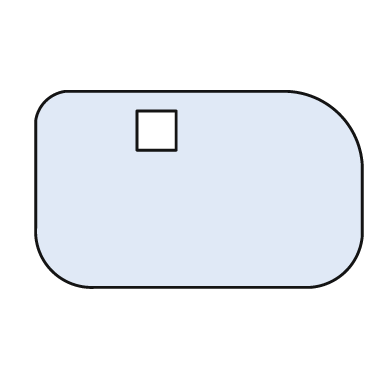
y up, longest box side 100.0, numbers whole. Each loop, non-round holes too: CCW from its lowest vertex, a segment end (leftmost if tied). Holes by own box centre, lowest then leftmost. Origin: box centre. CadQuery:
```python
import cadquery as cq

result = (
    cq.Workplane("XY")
    .moveTo(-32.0, -30.0)
    .lineTo(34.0, -30.0)
    .threePointArc((45.0, -25.0), (50.0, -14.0))
    .lineTo(50.0, 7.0)
    .threePointArc((43.0, 23.0), (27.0, 30.0))
    .lineTo(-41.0, 30.0)
    .threePointArc((-47.0, 27.0), (-50.0, 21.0))
    .lineTo(-50.0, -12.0)
    .threePointArc((-45.0, -25.0), (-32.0, -30.0))
    .close()
    .moveTo(-19.0, 12.0)
    .lineTo(-7.0, 12.0)
    .lineTo(-7.0, 24.0)
    .lineTo(-19.0, 24.0)
    .close()
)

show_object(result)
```